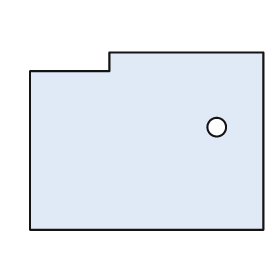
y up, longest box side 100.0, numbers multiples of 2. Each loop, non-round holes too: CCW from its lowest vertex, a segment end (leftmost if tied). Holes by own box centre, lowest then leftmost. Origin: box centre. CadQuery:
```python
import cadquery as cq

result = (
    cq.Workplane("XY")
    .moveTo(-50.0, -38.0)
    .lineTo(50.0, -38.0)
    .lineTo(50.0, 38.0)
    .lineTo(-16.0, 38.0)
    .lineTo(-16.0, 30.0)
    .lineTo(-50.0, 30.0)
    .close()
    .moveTo(30.0, 6.0)
    .circle(4.0)
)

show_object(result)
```